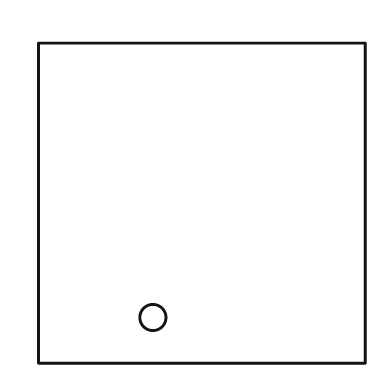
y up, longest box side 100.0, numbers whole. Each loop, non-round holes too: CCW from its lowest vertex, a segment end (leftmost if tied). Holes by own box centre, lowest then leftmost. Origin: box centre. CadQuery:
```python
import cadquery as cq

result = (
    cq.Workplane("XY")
    .moveTo(-50.0, -49.0)
    .lineTo(50.0, -49.0)
    .lineTo(50.0, 49.0)
    .lineTo(-50.0, 49.0)
    .close()
    .moveTo(-15.0, -35.0)
    .circle(4.0)
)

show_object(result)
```